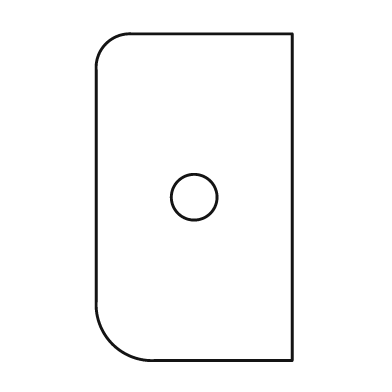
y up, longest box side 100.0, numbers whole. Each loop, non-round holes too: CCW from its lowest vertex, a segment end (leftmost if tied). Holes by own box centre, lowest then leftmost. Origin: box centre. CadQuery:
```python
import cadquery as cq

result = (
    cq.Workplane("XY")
    .moveTo(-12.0, -50.0)
    .lineTo(30.0, -50.0)
    .lineTo(30.0, 50.0)
    .lineTo(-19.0, 50.0)
    .threePointArc((-27.0, 47.0), (-30.0, 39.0))
    .lineTo(-30.0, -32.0)
    .threePointArc((-25.0, -45.0), (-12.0, -50.0))
    .close()
    .moveTo(0.0, 0.0)
    .circle(7.0)
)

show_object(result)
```